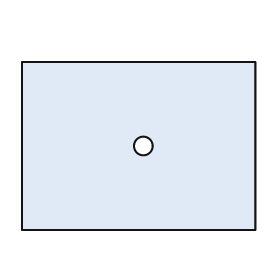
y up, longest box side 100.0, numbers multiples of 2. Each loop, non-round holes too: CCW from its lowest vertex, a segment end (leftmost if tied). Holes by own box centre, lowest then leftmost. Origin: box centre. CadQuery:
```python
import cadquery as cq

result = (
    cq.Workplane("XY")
    .moveTo(-50.0, -36.0)
    .lineTo(50.0, -36.0)
    .lineTo(50.0, 36.0)
    .lineTo(-50.0, 36.0)
    .close()
    .moveTo(2.0, 0.0)
    .circle(4.0)
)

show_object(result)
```